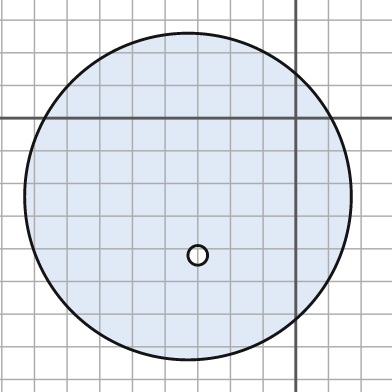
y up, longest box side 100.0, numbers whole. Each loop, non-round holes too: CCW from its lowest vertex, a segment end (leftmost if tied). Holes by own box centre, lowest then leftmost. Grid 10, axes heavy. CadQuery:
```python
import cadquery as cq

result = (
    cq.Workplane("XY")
    .moveTo(-33.0, -24.0)
    .circle(50.0)
    .moveTo(-30.0, -42.0)
    .circle(3.0)
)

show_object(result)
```